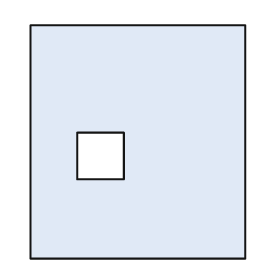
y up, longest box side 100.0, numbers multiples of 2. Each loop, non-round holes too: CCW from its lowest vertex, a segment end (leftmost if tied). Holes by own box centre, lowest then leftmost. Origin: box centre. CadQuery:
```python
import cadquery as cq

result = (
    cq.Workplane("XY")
    .moveTo(-46.0, -50.0)
    .lineTo(46.0, -50.0)
    .lineTo(46.0, 50.0)
    .lineTo(-46.0, 50.0)
    .close()
    .moveTo(-26.0, -16.0)
    .lineTo(-6.0, -16.0)
    .lineTo(-6.0, 4.0)
    .lineTo(-26.0, 4.0)
    .close()
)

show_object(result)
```